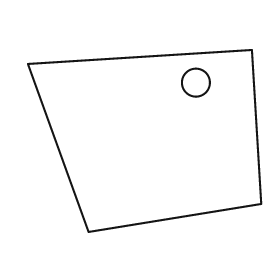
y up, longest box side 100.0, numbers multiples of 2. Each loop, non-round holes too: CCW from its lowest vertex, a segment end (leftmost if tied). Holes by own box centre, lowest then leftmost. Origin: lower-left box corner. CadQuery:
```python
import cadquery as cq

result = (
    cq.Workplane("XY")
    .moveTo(26.0, 0.0)
    .lineTo(100.0, 12.0)
    .lineTo(96.0, 78.0)
    .lineTo(0.0, 72.0)
    .close()
    .moveTo(72.0, 64.0)
    .circle(6.0)
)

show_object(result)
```